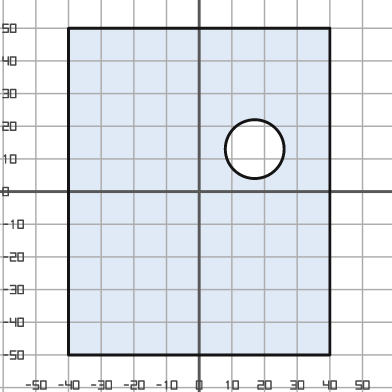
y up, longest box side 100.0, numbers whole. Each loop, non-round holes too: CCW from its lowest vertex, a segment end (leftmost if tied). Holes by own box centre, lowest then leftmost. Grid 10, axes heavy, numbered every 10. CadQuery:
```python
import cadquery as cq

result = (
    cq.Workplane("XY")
    .moveTo(-40.0, -50.0)
    .lineTo(40.0, -50.0)
    .lineTo(40.0, 50.0)
    .lineTo(-40.0, 50.0)
    .close()
    .moveTo(17.0, 13.0)
    .circle(9.0)
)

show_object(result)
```